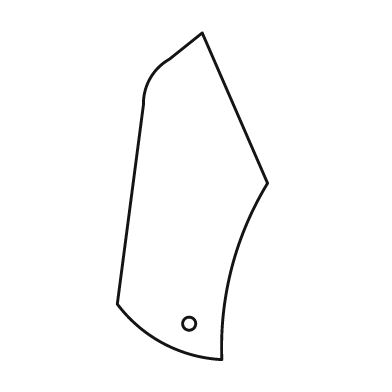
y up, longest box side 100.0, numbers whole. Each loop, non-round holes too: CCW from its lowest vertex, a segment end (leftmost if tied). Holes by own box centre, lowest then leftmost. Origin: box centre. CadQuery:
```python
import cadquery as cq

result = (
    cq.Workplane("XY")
    .moveTo(9.0, -50.0)
    .threePointArc((12.0, -22.0), (23.0, 4.0))
    .lineTo(3.0, 50.0)
    .lineTo(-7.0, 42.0)
    .threePointArc((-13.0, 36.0), (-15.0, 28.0))
    .lineTo(-23.0, -33.0)
    .threePointArc((-9.0, -45.0), (9.0, -50.0))
    .close()
    .moveTo(-1.0, -39.0)
    .circle(2.0)
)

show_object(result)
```